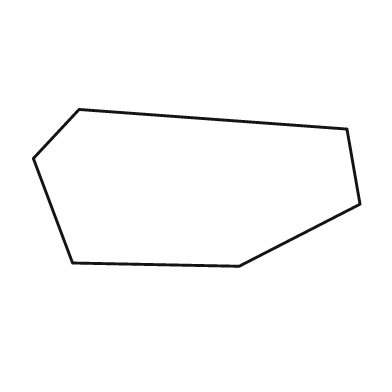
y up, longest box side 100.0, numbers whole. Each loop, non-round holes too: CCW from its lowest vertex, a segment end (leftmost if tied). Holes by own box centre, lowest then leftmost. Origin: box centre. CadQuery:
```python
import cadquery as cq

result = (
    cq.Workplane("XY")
    .moveTo(13.0, -24.0)
    .lineTo(50.0, -5.0)
    .lineTo(46.0, 18.0)
    .lineTo(-36.0, 24.0)
    .lineTo(-50.0, 9.0)
    .lineTo(-38.0, -23.0)
    .close()
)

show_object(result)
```